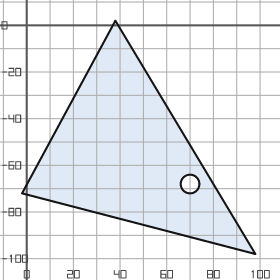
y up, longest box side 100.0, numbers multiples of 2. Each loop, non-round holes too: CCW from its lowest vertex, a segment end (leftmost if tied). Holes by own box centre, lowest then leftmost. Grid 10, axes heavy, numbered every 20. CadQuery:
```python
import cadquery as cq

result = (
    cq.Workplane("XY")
    .moveTo(98.0, -98.0)
    .lineTo(38.0, 2.0)
    .lineTo(-2.0, -72.0)
    .close()
    .moveTo(70.0, -68.0)
    .circle(4.0)
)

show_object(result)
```